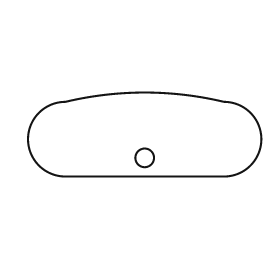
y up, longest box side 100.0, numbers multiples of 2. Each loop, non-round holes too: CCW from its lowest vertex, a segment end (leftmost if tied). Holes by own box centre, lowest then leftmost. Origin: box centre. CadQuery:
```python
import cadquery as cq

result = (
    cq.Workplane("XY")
    .moveTo(-34.0, -18.0)
    .lineTo(34.0, -18.0)
    .threePointArc((50.0, -2.0), (34.0, 14.0))
    .threePointArc((0.0, 18.0), (-34.0, 14.0))
    .threePointArc((-50.0, -2.0), (-34.0, -18.0))
    .close()
    .moveTo(0.0, -10.0)
    .circle(4.0)
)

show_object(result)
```